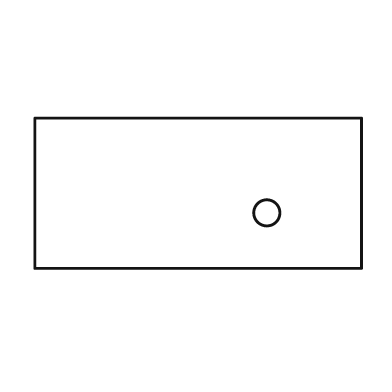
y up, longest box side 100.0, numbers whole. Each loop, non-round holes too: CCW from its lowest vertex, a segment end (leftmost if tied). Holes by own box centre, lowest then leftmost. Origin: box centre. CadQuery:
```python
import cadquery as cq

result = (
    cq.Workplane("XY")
    .moveTo(-50.0, -23.0)
    .lineTo(50.0, -23.0)
    .lineTo(50.0, 23.0)
    .lineTo(-50.0, 23.0)
    .close()
    .moveTo(21.0, -6.0)
    .circle(4.0)
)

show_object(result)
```